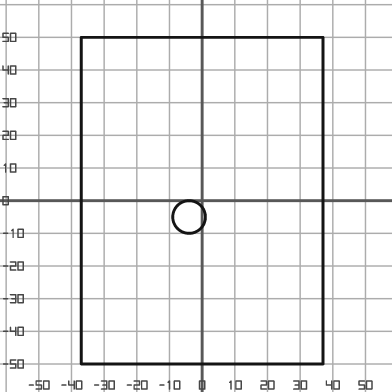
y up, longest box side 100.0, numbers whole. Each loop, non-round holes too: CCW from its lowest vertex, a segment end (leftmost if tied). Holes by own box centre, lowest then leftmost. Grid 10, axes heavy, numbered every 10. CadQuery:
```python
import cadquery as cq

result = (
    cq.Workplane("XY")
    .moveTo(-37.0, -50.0)
    .lineTo(37.0, -50.0)
    .lineTo(37.0, 50.0)
    .lineTo(-37.0, 50.0)
    .close()
    .moveTo(-4.0, -5.0)
    .circle(5.0)
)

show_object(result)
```